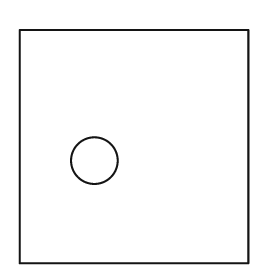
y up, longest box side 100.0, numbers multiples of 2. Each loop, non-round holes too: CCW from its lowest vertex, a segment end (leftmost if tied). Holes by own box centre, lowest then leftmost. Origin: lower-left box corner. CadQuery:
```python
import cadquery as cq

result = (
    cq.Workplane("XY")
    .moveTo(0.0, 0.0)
    .lineTo(98.0, 0.0)
    .lineTo(98.0, 100.0)
    .lineTo(0.0, 100.0)
    .close()
    .moveTo(32.0, 44.0)
    .circle(10.0)
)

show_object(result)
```